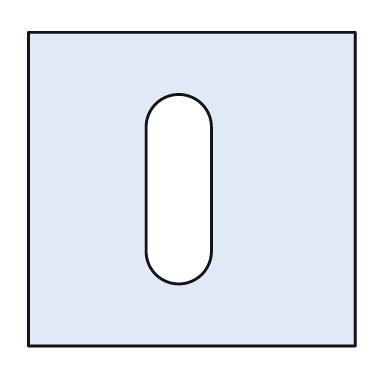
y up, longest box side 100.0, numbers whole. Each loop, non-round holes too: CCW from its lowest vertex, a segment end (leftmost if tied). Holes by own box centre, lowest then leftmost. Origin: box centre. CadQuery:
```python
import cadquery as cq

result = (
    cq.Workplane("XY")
    .moveTo(-50.0, -48.0)
    .lineTo(50.0, -48.0)
    .lineTo(50.0, 48.0)
    .lineTo(-50.0, 48.0)
    .close()
    .moveTo(-14.0, -19.0)
    .threePointArc((-4.0, -29.0), (6.0, -19.0))
    .lineTo(6.0, 19.0)
    .threePointArc((-4.0, 29.0), (-14.0, 19.0))
    .close()
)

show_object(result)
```